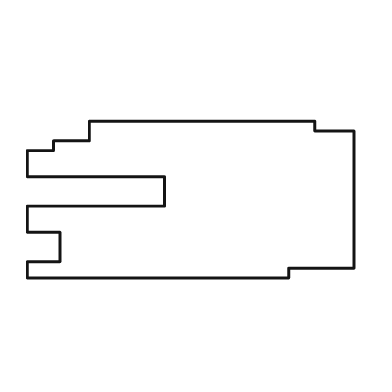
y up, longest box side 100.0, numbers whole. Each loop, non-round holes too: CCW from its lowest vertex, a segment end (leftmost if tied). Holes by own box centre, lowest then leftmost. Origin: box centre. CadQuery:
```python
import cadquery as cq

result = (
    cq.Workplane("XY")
    .moveTo(-50.0, -24.0)
    .lineTo(30.0, -24.0)
    .lineTo(30.0, -21.0)
    .lineTo(50.0, -21.0)
    .lineTo(50.0, 21.0)
    .lineTo(38.0, 21.0)
    .lineTo(38.0, 24.0)
    .lineTo(-31.0, 24.0)
    .lineTo(-31.0, 18.0)
    .lineTo(-42.0, 18.0)
    .lineTo(-42.0, 15.0)
    .lineTo(-50.0, 15.0)
    .lineTo(-50.0, 7.0)
    .lineTo(-8.0, 7.0)
    .lineTo(-8.0, -2.0)
    .lineTo(-50.0, -2.0)
    .lineTo(-50.0, -10.0)
    .lineTo(-40.0, -10.0)
    .lineTo(-40.0, -19.0)
    .lineTo(-50.0, -19.0)
    .close()
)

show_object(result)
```